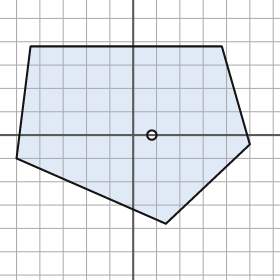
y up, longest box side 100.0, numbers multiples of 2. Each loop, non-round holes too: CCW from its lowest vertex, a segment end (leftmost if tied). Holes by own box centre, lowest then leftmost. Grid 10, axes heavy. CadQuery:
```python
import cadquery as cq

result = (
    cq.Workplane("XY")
    .moveTo(14.0, -38.0)
    .lineTo(50.0, -4.0)
    .lineTo(38.0, 38.0)
    .lineTo(-44.0, 38.0)
    .lineTo(-50.0, -10.0)
    .close()
    .moveTo(8.0, 0.0)
    .circle(2.0)
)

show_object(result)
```